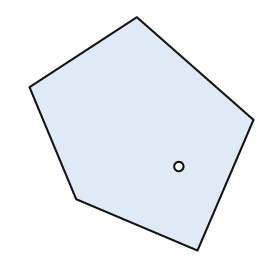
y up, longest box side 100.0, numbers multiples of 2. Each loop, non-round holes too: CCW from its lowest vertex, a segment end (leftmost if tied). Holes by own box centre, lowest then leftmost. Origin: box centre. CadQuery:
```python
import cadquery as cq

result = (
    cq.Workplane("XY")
    .moveTo(24.0, -50.0)
    .lineTo(48.0, 6.0)
    .lineTo(-2.0, 50.0)
    .lineTo(-48.0, 20.0)
    .lineTo(-28.0, -28.0)
    .close()
    .moveTo(16.0, -14.0)
    .circle(2.0)
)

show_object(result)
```